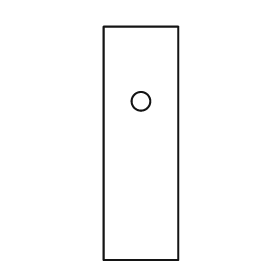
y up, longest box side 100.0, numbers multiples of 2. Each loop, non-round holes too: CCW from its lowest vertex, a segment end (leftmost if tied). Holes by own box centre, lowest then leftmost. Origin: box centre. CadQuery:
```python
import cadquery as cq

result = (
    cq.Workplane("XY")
    .moveTo(-16.0, -50.0)
    .lineTo(16.0, -50.0)
    .lineTo(16.0, 50.0)
    .lineTo(-16.0, 50.0)
    .close()
    .moveTo(0.0, 18.0)
    .circle(4.0)
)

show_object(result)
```